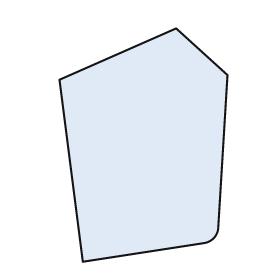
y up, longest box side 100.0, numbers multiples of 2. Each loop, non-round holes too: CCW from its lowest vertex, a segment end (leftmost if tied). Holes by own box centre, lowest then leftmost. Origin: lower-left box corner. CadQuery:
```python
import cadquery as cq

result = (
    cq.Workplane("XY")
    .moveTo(10.0, 0.0)
    .lineTo(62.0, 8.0)
    .threePointArc((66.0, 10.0), (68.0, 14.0))
    .lineTo(72.0, 80.0)
    .lineTo(50.0, 100.0)
    .lineTo(0.0, 78.0)
    .close()
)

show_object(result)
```